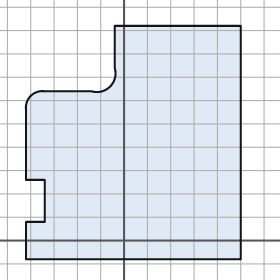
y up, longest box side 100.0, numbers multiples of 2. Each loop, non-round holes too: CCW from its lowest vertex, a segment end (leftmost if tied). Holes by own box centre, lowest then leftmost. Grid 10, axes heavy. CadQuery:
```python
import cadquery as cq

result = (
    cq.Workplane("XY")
    .moveTo(-42.0, -8.0)
    .lineTo(50.0, -8.0)
    .lineTo(50.0, 92.0)
    .lineTo(-4.0, 92.0)
    .lineTo(-4.0, 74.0)
    .threePointArc((-6.0, 66.0), (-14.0, 64.0))
    .lineTo(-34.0, 64.0)
    .threePointArc((-40.0, 62.0), (-42.0, 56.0))
    .lineTo(-42.0, 26.0)
    .lineTo(-34.0, 26.0)
    .lineTo(-34.0, 8.0)
    .lineTo(-42.0, 8.0)
    .close()
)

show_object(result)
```